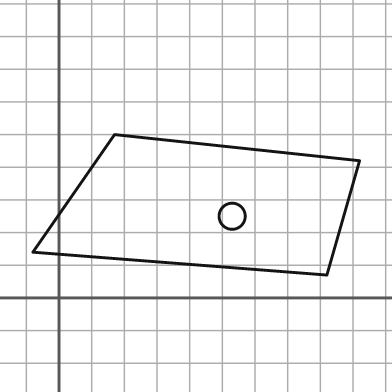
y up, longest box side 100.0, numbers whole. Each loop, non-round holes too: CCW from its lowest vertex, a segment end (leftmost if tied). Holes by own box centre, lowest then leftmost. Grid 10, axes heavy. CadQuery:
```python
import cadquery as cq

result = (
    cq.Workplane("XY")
    .moveTo(82.0, 7.0)
    .lineTo(92.0, 42.0)
    .lineTo(17.0, 50.0)
    .lineTo(-8.0, 14.0)
    .close()
    .moveTo(53.0, 25.0)
    .circle(4.0)
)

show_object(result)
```